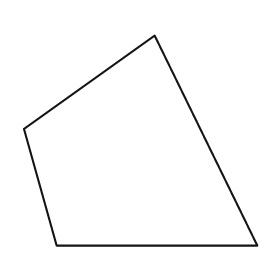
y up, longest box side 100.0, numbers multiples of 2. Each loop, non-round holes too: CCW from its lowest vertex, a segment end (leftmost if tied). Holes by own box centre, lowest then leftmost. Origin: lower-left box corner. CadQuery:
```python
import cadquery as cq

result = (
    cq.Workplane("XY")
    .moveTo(14.0, 0.0)
    .lineTo(100.0, 0.0)
    .lineTo(56.0, 90.0)
    .lineTo(0.0, 50.0)
    .close()
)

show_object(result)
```